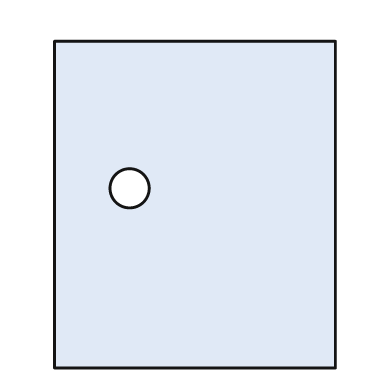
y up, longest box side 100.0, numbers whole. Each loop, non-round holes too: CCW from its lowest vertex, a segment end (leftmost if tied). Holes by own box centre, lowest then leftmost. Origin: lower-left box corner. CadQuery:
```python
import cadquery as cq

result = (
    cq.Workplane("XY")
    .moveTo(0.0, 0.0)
    .lineTo(86.0, 0.0)
    .lineTo(86.0, 100.0)
    .lineTo(0.0, 100.0)
    .close()
    .moveTo(23.0, 55.0)
    .circle(6.0)
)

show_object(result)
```